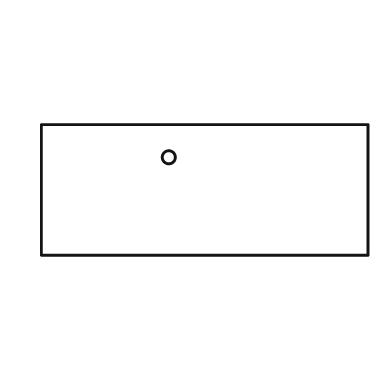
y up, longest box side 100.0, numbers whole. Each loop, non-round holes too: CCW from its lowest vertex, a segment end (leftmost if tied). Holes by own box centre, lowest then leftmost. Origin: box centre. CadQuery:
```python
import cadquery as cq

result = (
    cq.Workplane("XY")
    .moveTo(-50.0, -20.0)
    .lineTo(50.0, -20.0)
    .lineTo(50.0, 20.0)
    .lineTo(-50.0, 20.0)
    .close()
    .moveTo(-11.0, 10.0)
    .circle(2.0)
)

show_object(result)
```